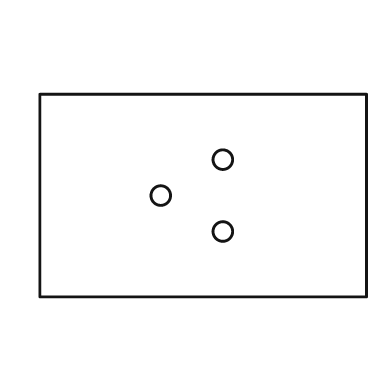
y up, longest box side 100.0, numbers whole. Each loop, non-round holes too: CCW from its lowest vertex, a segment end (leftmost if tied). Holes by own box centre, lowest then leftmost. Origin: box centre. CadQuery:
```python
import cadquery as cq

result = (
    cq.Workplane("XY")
    .moveTo(-50.0, -31.0)
    .lineTo(50.0, -31.0)
    .lineTo(50.0, 31.0)
    .lineTo(-50.0, 31.0)
    .close()
    .moveTo(6.0, -11.0)
    .circle(3.0)
    .moveTo(-13.0, 0.0)
    .circle(3.0)
    .moveTo(6.0, 11.0)
    .circle(3.0)
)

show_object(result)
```